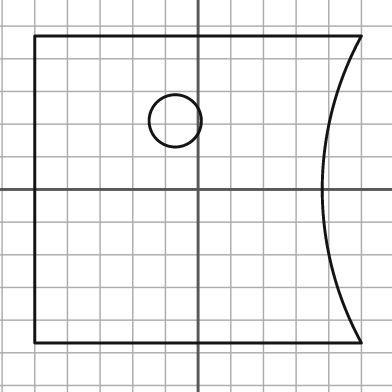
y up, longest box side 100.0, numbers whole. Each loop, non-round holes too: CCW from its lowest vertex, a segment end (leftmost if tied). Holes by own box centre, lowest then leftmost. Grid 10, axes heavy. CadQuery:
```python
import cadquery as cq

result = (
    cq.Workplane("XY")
    .moveTo(-50.0, -47.0)
    .lineTo(50.0, -47.0)
    .threePointArc((38.0, 0.0), (50.0, 47.0))
    .lineTo(-50.0, 47.0)
    .close()
    .moveTo(-7.0, 21.0)
    .circle(8.0)
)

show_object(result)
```